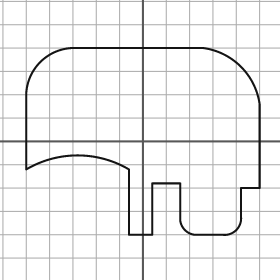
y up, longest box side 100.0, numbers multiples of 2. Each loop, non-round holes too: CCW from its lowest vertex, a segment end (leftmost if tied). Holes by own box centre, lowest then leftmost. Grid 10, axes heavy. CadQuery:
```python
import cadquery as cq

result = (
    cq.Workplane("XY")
    .moveTo(-6.0, -40.0)
    .lineTo(4.0, -40.0)
    .lineTo(4.0, -18.0)
    .lineTo(16.0, -18.0)
    .lineTo(16.0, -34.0)
    .threePointArc((18.0, -38.0), (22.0, -40.0))
    .lineTo(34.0, -40.0)
    .threePointArc((40.0, -38.0), (42.0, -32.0))
    .lineTo(42.0, -20.0)
    .lineTo(50.0, -20.0)
    .lineTo(50.0, 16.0)
    .threePointArc((42.0, 32.0), (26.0, 40.0))
    .lineTo(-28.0, 40.0)
    .threePointArc((-44.0, 34.0), (-50.0, 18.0))
    .lineTo(-50.0, -12.0)
    .threePointArc((-28.0, -6.0), (-6.0, -12.0))
    .close()
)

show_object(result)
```